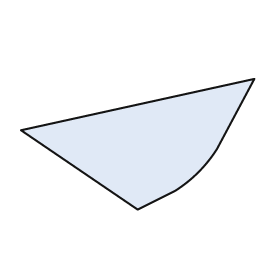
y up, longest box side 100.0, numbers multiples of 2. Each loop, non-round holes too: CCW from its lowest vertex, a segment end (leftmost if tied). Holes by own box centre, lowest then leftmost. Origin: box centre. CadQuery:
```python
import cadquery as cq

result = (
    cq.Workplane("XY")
    .moveTo(0.0, -28.0)
    .lineTo(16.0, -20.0)
    .threePointArc((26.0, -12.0), (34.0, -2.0))
    .lineTo(50.0, 28.0)
    .lineTo(-50.0, 6.0)
    .close()
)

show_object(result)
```